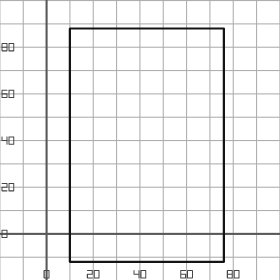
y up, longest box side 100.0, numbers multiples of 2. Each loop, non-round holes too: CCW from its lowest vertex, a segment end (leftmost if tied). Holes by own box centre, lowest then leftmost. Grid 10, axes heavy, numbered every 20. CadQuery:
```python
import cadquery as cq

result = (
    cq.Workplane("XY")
    .moveTo(10.0, -12.0)
    .lineTo(76.0, -12.0)
    .lineTo(76.0, 88.0)
    .lineTo(10.0, 88.0)
    .close()
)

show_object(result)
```